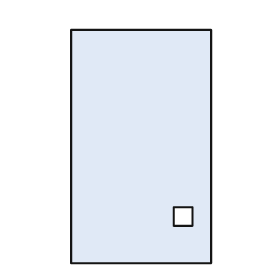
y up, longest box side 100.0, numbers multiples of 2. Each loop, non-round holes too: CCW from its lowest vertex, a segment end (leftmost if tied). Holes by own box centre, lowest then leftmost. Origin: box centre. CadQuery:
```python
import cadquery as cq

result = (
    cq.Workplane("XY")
    .moveTo(-30.0, -50.0)
    .lineTo(30.0, -50.0)
    .lineTo(30.0, 50.0)
    .lineTo(-30.0, 50.0)
    .close()
    .moveTo(14.0, -34.0)
    .lineTo(22.0, -34.0)
    .lineTo(22.0, -26.0)
    .lineTo(14.0, -26.0)
    .close()
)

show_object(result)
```